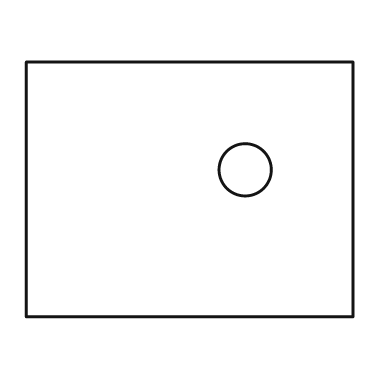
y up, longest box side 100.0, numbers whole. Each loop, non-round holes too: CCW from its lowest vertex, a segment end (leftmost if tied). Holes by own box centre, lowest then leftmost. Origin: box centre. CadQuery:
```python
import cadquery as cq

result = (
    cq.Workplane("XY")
    .moveTo(-50.0, -39.0)
    .lineTo(50.0, -39.0)
    .lineTo(50.0, 39.0)
    .lineTo(-50.0, 39.0)
    .close()
    .moveTo(17.0, 6.0)
    .circle(8.0)
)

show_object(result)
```